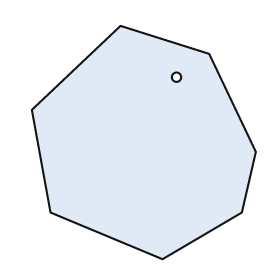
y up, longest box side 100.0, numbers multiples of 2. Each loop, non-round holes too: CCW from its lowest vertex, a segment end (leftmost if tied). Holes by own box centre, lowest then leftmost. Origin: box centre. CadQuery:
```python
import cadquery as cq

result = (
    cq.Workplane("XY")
    .moveTo(8.0, -50.0)
    .lineTo(42.0, -30.0)
    .lineTo(48.0, -4.0)
    .lineTo(28.0, 38.0)
    .lineTo(-10.0, 50.0)
    .lineTo(-48.0, 14.0)
    .lineTo(-40.0, -30.0)
    .close()
    .moveTo(14.0, 28.0)
    .circle(2.0)
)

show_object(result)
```